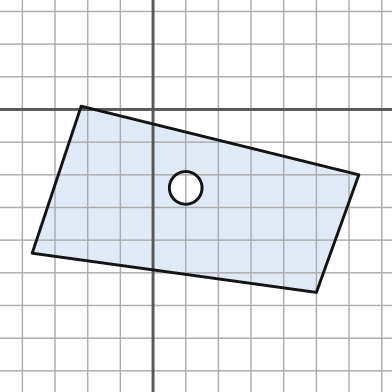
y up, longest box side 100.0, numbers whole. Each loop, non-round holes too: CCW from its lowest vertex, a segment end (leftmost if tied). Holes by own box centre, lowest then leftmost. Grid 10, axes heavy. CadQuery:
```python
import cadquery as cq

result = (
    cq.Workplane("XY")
    .moveTo(50.0, -56.0)
    .lineTo(63.0, -20.0)
    .lineTo(-22.0, 1.0)
    .lineTo(-37.0, -44.0)
    .close()
    .moveTo(10.0, -24.0)
    .circle(5.0)
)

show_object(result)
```